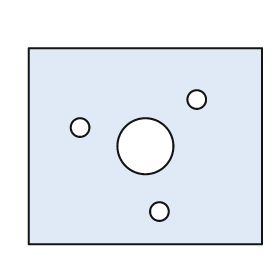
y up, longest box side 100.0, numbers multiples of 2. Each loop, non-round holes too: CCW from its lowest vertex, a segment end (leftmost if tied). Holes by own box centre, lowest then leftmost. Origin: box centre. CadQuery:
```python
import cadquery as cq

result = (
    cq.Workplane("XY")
    .moveTo(-50.0, -42.0)
    .lineTo(50.0, -42.0)
    .lineTo(50.0, 42.0)
    .lineTo(-50.0, 42.0)
    .close()
    .moveTo(6.0, -28.0)
    .circle(4.0)
    .moveTo(0.0, 0.0)
    .circle(12.0)
    .moveTo(-28.0, 8.0)
    .circle(4.0)
    .moveTo(22.0, 20.0)
    .circle(4.0)
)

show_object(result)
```